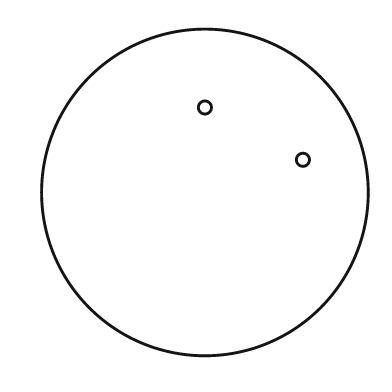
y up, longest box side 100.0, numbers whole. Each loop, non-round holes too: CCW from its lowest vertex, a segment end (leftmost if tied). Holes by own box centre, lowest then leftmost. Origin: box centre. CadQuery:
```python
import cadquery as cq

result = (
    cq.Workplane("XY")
    .moveTo(0.0, 0.0)
    .circle(50.0)
    .moveTo(30.0, 10.0)
    .circle(2.0)
    .moveTo(0.0, 26.0)
    .circle(2.0)
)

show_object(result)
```